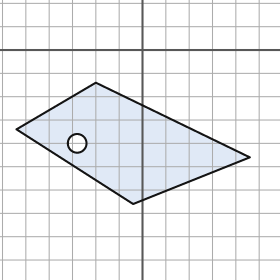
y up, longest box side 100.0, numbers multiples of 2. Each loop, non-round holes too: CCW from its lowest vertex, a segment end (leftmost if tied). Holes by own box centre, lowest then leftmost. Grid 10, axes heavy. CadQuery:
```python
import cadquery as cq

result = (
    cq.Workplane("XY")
    .moveTo(-4.0, -66.0)
    .lineTo(46.0, -46.0)
    .lineTo(-20.0, -14.0)
    .lineTo(-54.0, -34.0)
    .close()
    .moveTo(-28.0, -40.0)
    .circle(4.0)
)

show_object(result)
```